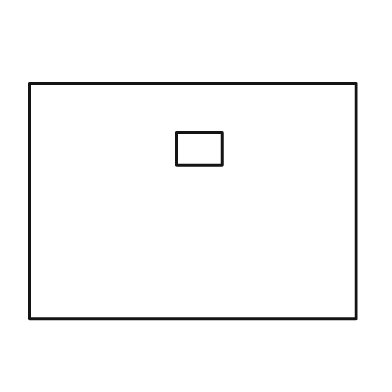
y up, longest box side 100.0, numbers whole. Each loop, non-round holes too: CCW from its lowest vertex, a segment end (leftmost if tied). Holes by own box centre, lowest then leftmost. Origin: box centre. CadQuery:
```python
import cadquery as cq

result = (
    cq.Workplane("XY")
    .moveTo(-50.0, -36.0)
    .lineTo(50.0, -36.0)
    .lineTo(50.0, 36.0)
    .lineTo(-50.0, 36.0)
    .close()
    .moveTo(-5.0, 11.0)
    .lineTo(9.0, 11.0)
    .lineTo(9.0, 21.0)
    .lineTo(-5.0, 21.0)
    .close()
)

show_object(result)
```